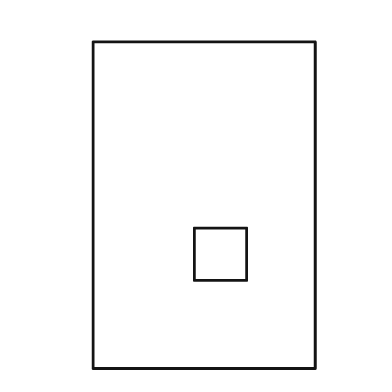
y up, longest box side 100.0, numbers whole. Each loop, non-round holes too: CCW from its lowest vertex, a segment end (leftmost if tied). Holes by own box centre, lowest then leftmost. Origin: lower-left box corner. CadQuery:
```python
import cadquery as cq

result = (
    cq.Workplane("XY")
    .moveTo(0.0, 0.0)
    .lineTo(68.0, 0.0)
    .lineTo(68.0, 100.0)
    .lineTo(0.0, 100.0)
    .close()
    .moveTo(31.0, 27.0)
    .lineTo(47.0, 27.0)
    .lineTo(47.0, 43.0)
    .lineTo(31.0, 43.0)
    .close()
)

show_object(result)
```